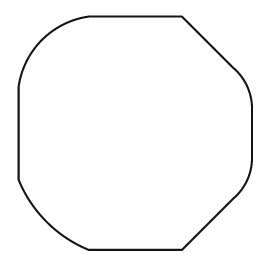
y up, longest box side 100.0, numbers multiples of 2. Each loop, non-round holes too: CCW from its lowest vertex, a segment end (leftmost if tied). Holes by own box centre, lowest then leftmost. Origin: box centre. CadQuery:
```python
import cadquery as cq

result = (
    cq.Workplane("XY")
    .moveTo(-20.0, -50.0)
    .lineTo(20.0, -50.0)
    .lineTo(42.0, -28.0)
    .threePointArc((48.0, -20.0), (50.0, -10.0))
    .lineTo(50.0, 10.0)
    .threePointArc((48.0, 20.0), (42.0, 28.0))
    .lineTo(20.0, 50.0)
    .lineTo(-20.0, 50.0)
    .threePointArc((-40.0, 40.0), (-50.0, 20.0))
    .lineTo(-50.0, -20.0)
    .threePointArc((-38.0, -38.0), (-20.0, -50.0))
    .close()
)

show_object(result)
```